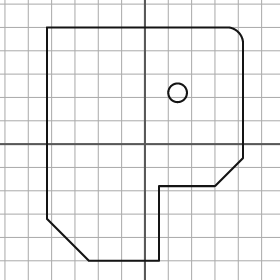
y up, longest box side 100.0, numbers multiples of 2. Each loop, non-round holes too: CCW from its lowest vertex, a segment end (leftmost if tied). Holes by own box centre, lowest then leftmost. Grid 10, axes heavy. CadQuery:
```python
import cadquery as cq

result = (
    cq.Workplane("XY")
    .moveTo(-24.0, -50.0)
    .lineTo(6.0, -50.0)
    .lineTo(6.0, -18.0)
    .lineTo(30.0, -18.0)
    .lineTo(42.0, -6.0)
    .lineTo(42.0, 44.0)
    .threePointArc((40.0, 48.0), (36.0, 50.0))
    .lineTo(-42.0, 50.0)
    .lineTo(-42.0, -32.0)
    .close()
    .moveTo(14.0, 22.0)
    .circle(4.0)
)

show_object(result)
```